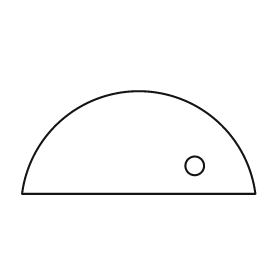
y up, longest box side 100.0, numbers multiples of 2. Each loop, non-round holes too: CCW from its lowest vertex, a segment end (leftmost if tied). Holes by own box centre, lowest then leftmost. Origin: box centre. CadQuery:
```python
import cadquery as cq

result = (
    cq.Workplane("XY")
    .moveTo(-50.0, -22.0)
    .lineTo(50.0, -22.0)
    .threePointArc((0.0, 22.0), (-50.0, -22.0))
    .close()
    .moveTo(24.0, -10.0)
    .circle(4.0)
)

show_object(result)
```